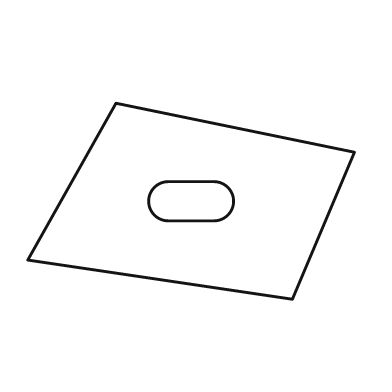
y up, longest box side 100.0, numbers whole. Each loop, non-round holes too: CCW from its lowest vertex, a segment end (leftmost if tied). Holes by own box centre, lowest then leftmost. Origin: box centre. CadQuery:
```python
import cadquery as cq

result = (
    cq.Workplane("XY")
    .moveTo(31.0, -30.0)
    .lineTo(50.0, 15.0)
    .lineTo(-23.0, 30.0)
    .lineTo(-50.0, -18.0)
    .close()
    .moveTo(-7.0, -6.0)
    .lineTo(7.0, -6.0)
    .threePointArc((13.0, 0.0), (7.0, 6.0))
    .lineTo(-7.0, 6.0)
    .threePointArc((-13.0, 0.0), (-7.0, -6.0))
    .close()
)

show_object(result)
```